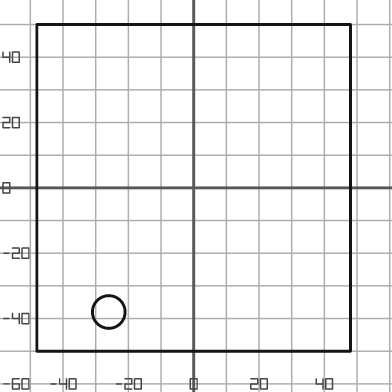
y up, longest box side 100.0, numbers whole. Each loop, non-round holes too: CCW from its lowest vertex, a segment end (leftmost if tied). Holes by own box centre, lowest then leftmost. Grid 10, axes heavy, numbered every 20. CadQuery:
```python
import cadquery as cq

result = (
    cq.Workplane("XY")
    .moveTo(-48.0, -50.0)
    .lineTo(48.0, -50.0)
    .lineTo(48.0, 50.0)
    .lineTo(-48.0, 50.0)
    .close()
    .moveTo(-26.0, -38.0)
    .circle(5.0)
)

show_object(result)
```